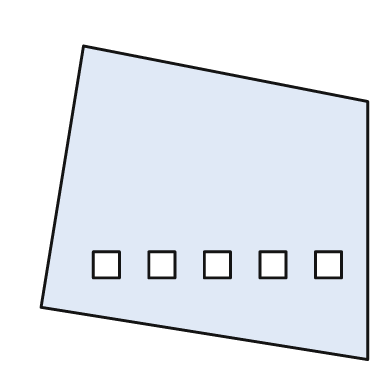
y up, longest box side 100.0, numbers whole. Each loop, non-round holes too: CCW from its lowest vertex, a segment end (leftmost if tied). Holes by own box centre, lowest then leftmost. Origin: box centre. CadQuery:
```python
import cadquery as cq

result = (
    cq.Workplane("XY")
    .moveTo(50.0, -48.0)
    .lineTo(50.0, 31.0)
    .lineTo(-37.0, 48.0)
    .lineTo(-50.0, -32.0)
    .close()
    .moveTo(-34.0, -23.0)
    .lineTo(-26.0, -23.0)
    .lineTo(-26.0, -15.0)
    .lineTo(-34.0, -15.0)
    .close()
    .moveTo(-17.0, -23.0)
    .lineTo(-9.0, -23.0)
    .lineTo(-9.0, -15.0)
    .lineTo(-17.0, -15.0)
    .close()
    .moveTo(0.0, -23.0)
    .lineTo(8.0, -23.0)
    .lineTo(8.0, -15.0)
    .lineTo(0.0, -15.0)
    .close()
    .moveTo(17.0, -23.0)
    .lineTo(25.0, -23.0)
    .lineTo(25.0, -15.0)
    .lineTo(17.0, -15.0)
    .close()
    .moveTo(34.0, -23.0)
    .lineTo(42.0, -23.0)
    .lineTo(42.0, -15.0)
    .lineTo(34.0, -15.0)
    .close()
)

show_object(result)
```